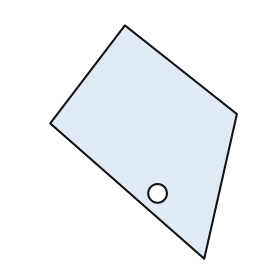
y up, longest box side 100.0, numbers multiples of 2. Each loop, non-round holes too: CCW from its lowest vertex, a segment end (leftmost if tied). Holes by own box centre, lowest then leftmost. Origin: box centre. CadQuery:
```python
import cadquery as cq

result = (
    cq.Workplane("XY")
    .moveTo(26.0, -50.0)
    .lineTo(40.0, 12.0)
    .lineTo(-8.0, 50.0)
    .lineTo(-40.0, 8.0)
    .close()
    .moveTo(6.0, -22.0)
    .circle(4.0)
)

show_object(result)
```